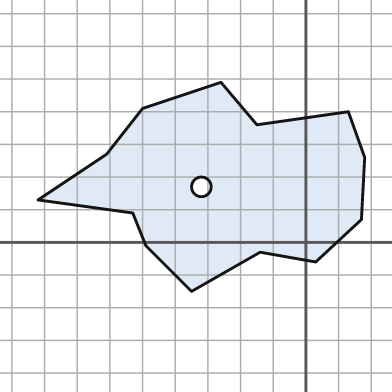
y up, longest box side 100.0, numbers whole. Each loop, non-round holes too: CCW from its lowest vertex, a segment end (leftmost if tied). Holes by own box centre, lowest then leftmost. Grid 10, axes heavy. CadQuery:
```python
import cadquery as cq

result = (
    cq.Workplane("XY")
    .moveTo(-35.0, -15.0)
    .lineTo(-14.0, -3.0)
    .lineTo(3.0, -6.0)
    .lineTo(17.0, 7.0)
    .lineTo(18.0, 26.0)
    .lineTo(13.0, 40.0)
    .lineTo(-15.0, 36.0)
    .lineTo(-26.0, 49.0)
    .lineTo(-50.0, 41.0)
    .lineTo(-61.0, 27.0)
    .lineTo(-82.0, 13.0)
    .lineTo(-53.0, 9.0)
    .lineTo(-49.0, -1.0)
    .close()
    .moveTo(-32.0, 17.0)
    .circle(3.0)
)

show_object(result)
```